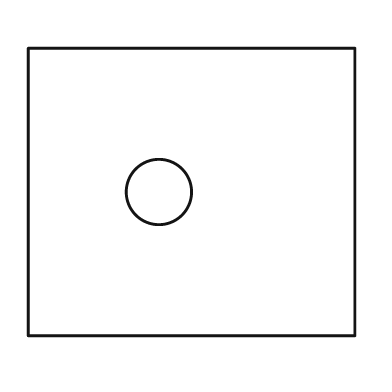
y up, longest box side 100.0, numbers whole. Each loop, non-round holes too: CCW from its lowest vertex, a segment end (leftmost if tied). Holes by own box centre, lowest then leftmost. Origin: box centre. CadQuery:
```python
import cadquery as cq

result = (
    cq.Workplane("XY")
    .moveTo(-50.0, -44.0)
    .lineTo(50.0, -44.0)
    .lineTo(50.0, 44.0)
    .lineTo(-50.0, 44.0)
    .close()
    .moveTo(-10.0, 0.0)
    .circle(10.0)
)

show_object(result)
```